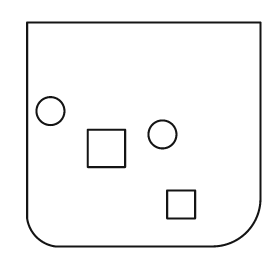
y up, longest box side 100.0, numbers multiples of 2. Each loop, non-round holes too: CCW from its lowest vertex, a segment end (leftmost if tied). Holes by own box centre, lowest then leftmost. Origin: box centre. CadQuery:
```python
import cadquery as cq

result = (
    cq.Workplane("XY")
    .moveTo(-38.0, -48.0)
    .lineTo(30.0, -48.0)
    .threePointArc((44.0, -42.0), (50.0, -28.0))
    .lineTo(50.0, 48.0)
    .lineTo(-50.0, 48.0)
    .lineTo(-50.0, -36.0)
    .threePointArc((-46.0, -44.0), (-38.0, -48.0))
    .close()
    .moveTo(10.0, -36.0)
    .lineTo(22.0, -36.0)
    .lineTo(22.0, -24.0)
    .lineTo(10.0, -24.0)
    .close()
    .moveTo(-24.0, -14.0)
    .lineTo(-8.0, -14.0)
    .lineTo(-8.0, 2.0)
    .lineTo(-24.0, 2.0)
    .close()
    .moveTo(8.0, 0.0)
    .circle(6.0)
    .moveTo(-40.0, 10.0)
    .circle(6.0)
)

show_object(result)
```